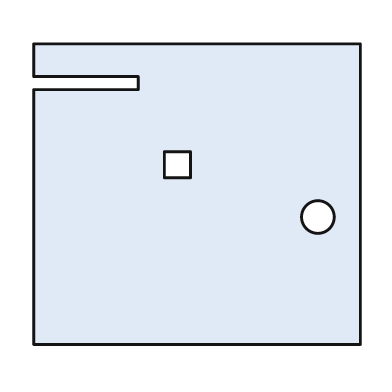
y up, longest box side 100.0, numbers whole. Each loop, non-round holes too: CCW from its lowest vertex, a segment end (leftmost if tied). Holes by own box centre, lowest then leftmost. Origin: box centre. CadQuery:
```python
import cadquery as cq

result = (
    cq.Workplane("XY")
    .moveTo(-50.0, -46.0)
    .lineTo(50.0, -46.0)
    .lineTo(50.0, 46.0)
    .lineTo(-50.0, 46.0)
    .lineTo(-50.0, 36.0)
    .lineTo(-18.0, 36.0)
    .lineTo(-18.0, 32.0)
    .lineTo(-50.0, 32.0)
    .close()
    .moveTo(37.0, -7.0)
    .circle(5.0)
    .moveTo(-10.0, 5.0)
    .lineTo(-2.0, 5.0)
    .lineTo(-2.0, 13.0)
    .lineTo(-10.0, 13.0)
    .close()
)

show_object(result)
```